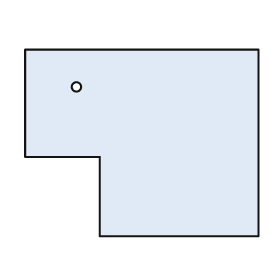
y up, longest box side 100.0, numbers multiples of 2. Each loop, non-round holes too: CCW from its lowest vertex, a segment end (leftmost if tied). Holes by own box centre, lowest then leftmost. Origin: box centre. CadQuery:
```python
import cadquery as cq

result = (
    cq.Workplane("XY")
    .moveTo(-18.0, -40.0)
    .lineTo(50.0, -40.0)
    .lineTo(50.0, 40.0)
    .lineTo(-50.0, 40.0)
    .lineTo(-50.0, -6.0)
    .lineTo(-18.0, -6.0)
    .close()
    .moveTo(-28.0, 24.0)
    .circle(2.0)
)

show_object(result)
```